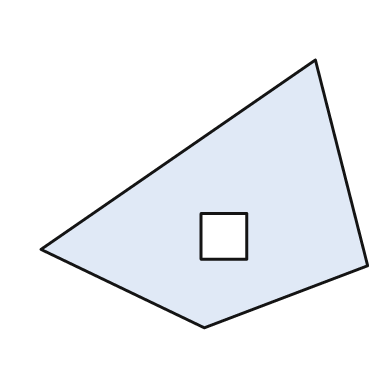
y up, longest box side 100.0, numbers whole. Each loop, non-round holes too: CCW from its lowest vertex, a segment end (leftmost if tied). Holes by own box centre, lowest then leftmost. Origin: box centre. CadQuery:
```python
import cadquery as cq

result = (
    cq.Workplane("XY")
    .moveTo(0.0, -41.0)
    .lineTo(50.0, -22.0)
    .lineTo(34.0, 41.0)
    .lineTo(-50.0, -17.0)
    .close()
    .moveTo(-1.0, -20.0)
    .lineTo(13.0, -20.0)
    .lineTo(13.0, -6.0)
    .lineTo(-1.0, -6.0)
    .close()
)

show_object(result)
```